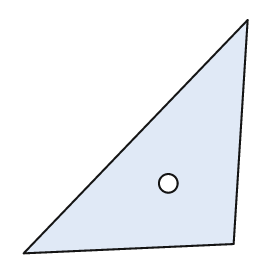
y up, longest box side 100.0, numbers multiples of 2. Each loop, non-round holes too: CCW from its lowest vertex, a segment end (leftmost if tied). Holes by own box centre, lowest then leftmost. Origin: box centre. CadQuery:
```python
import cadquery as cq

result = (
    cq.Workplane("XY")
    .moveTo(-48.0, -50.0)
    .lineTo(42.0, -46.0)
    .lineTo(48.0, 50.0)
    .close()
    .moveTo(14.0, -20.0)
    .circle(4.0)
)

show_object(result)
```